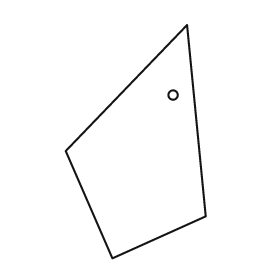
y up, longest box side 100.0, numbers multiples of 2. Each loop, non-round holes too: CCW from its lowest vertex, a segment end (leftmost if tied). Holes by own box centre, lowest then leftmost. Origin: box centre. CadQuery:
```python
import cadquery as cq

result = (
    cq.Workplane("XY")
    .moveTo(-10.0, -50.0)
    .lineTo(30.0, -32.0)
    .lineTo(22.0, 50.0)
    .lineTo(-30.0, -4.0)
    .close()
    .moveTo(16.0, 20.0)
    .circle(2.0)
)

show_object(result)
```